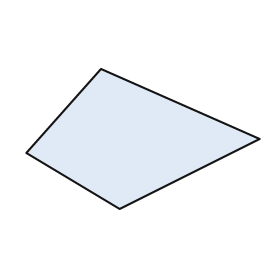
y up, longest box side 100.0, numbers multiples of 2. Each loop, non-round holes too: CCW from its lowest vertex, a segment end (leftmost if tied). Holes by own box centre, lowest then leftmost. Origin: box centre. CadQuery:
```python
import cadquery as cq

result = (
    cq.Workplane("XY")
    .moveTo(-10.0, -30.0)
    .lineTo(50.0, 0.0)
    .lineTo(-18.0, 30.0)
    .lineTo(-50.0, -6.0)
    .close()
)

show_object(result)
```